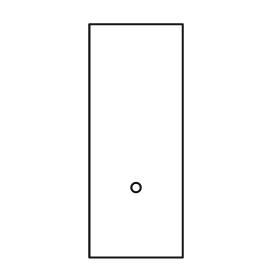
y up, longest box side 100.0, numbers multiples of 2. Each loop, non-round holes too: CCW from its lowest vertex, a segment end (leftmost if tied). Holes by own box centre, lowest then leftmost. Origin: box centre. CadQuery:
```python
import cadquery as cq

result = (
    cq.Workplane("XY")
    .moveTo(-20.0, -50.0)
    .lineTo(20.0, -50.0)
    .lineTo(20.0, 50.0)
    .lineTo(-20.0, 50.0)
    .close()
    .moveTo(0.0, -20.0)
    .circle(2.0)
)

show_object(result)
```